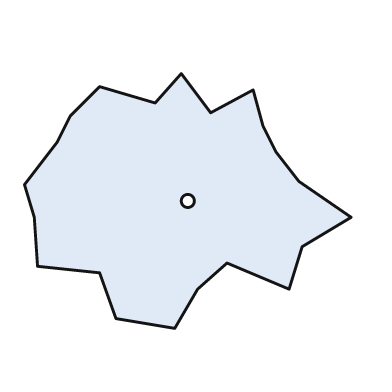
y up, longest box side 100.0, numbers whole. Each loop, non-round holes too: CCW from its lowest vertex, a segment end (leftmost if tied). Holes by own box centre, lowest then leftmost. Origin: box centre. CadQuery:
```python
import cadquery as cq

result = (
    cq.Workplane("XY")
    .moveTo(-4.0, -39.0)
    .lineTo(3.0, -27.0)
    .lineTo(12.0, -19.0)
    .lineTo(31.0, -27.0)
    .lineTo(35.0, -14.0)
    .lineTo(50.0, -5.0)
    .lineTo(34.0, 6.0)
    .lineTo(27.0, 15.0)
    .lineTo(23.0, 23.0)
    .lineTo(20.0, 34.0)
    .lineTo(7.0, 27.0)
    .lineTo(-2.0, 39.0)
    .lineTo(-10.0, 30.0)
    .lineTo(-27.0, 35.0)
    .lineTo(-36.0, 26.0)
    .lineTo(-40.0, 18.0)
    .lineTo(-50.0, 5.0)
    .lineTo(-47.0, -5.0)
    .lineTo(-46.0, -20.0)
    .lineTo(-27.0, -22.0)
    .lineTo(-22.0, -36.0)
    .close()
    .moveTo(0.0, 0.0)
    .circle(2.0)
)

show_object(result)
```